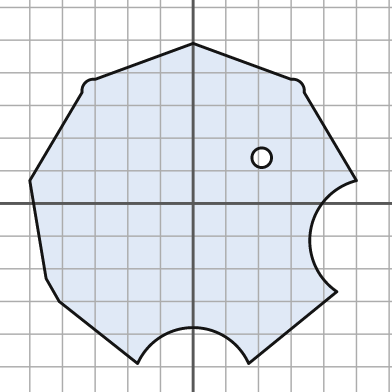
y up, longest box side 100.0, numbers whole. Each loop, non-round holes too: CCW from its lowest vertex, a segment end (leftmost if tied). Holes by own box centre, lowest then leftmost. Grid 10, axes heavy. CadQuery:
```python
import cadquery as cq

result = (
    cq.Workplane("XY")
    .moveTo(-17.0, -49.0)
    .threePointArc((0.0, -38.0), (17.0, -49.0))
    .lineTo(44.0, -27.0)
    .threePointArc((36.0, -8.0), (50.0, 7.0))
    .lineTo(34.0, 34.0)
    .threePointArc((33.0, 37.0), (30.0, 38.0))
    .lineTo(0.0, 49.0)
    .lineTo(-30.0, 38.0)
    .threePointArc((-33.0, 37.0), (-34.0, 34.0))
    .lineTo(-50.0, 7.0)
    .lineTo(-45.0, -23.0)
    .lineTo(-41.0, -30.0)
    .close()
    .moveTo(21.0, 14.0)
    .circle(3.0)
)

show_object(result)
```